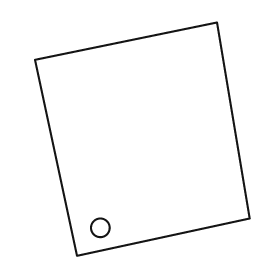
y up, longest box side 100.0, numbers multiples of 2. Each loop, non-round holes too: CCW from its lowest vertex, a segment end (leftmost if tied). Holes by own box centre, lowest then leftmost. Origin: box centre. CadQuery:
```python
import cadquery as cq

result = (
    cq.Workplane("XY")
    .moveTo(-28.0, -50.0)
    .lineTo(46.0, -34.0)
    .lineTo(32.0, 50.0)
    .lineTo(-46.0, 34.0)
    .close()
    .moveTo(-18.0, -38.0)
    .circle(4.0)
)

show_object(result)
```